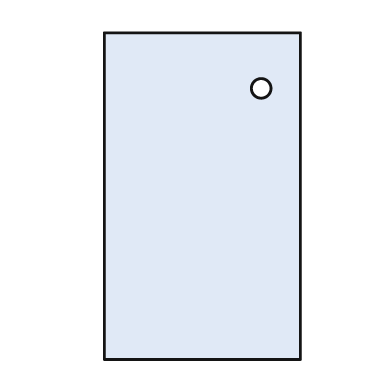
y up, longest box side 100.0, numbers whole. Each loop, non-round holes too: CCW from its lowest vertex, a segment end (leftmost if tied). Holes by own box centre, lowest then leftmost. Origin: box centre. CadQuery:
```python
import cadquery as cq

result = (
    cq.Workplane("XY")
    .moveTo(-30.0, -50.0)
    .lineTo(30.0, -50.0)
    .lineTo(30.0, 50.0)
    .lineTo(-30.0, 50.0)
    .close()
    .moveTo(18.0, 33.0)
    .circle(3.0)
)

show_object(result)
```